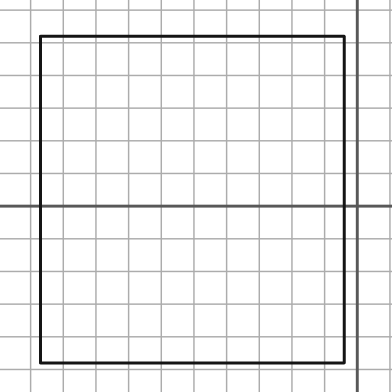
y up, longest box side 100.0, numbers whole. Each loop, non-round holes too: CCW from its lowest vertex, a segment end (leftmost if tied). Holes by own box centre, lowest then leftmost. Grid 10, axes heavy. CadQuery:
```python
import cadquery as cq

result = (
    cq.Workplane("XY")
    .moveTo(-97.0, -48.0)
    .lineTo(-4.0, -48.0)
    .lineTo(-4.0, 52.0)
    .lineTo(-97.0, 52.0)
    .close()
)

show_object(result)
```